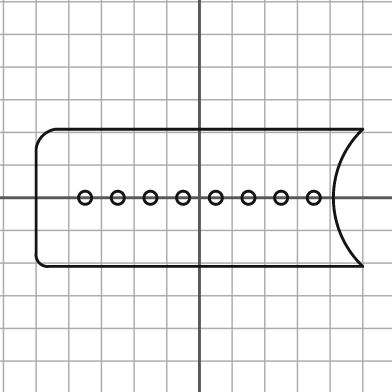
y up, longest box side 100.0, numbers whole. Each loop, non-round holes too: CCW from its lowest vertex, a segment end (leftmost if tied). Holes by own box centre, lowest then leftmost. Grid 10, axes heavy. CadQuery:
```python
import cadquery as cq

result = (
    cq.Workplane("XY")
    .moveTo(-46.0, -21.0)
    .lineTo(50.0, -21.0)
    .threePointArc((41.0, 0.0), (50.0, 21.0))
    .lineTo(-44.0, 21.0)
    .threePointArc((-48.0, 19.0), (-50.0, 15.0))
    .lineTo(-50.0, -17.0)
    .threePointArc((-49.0, -20.0), (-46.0, -21.0))
    .close()
    .moveTo(-35.0, 0.0)
    .circle(2.0)
    .moveTo(-25.0, 0.0)
    .circle(2.0)
    .moveTo(-15.0, 0.0)
    .circle(2.0)
    .moveTo(-5.0, 0.0)
    .circle(2.0)
    .moveTo(5.0, 0.0)
    .circle(2.0)
    .moveTo(15.0, 0.0)
    .circle(2.0)
    .moveTo(25.0, 0.0)
    .circle(2.0)
    .moveTo(35.0, 0.0)
    .circle(2.0)
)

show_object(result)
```